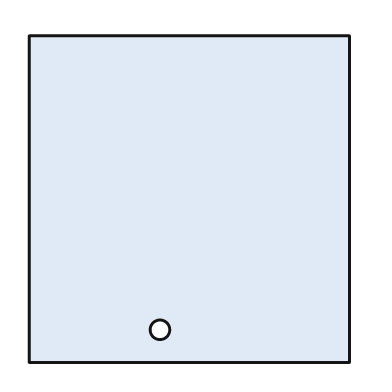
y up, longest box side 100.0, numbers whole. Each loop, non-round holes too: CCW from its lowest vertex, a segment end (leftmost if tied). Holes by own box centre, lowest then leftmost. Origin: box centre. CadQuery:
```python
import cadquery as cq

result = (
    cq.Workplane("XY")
    .moveTo(-49.0, -50.0)
    .lineTo(49.0, -50.0)
    .lineTo(49.0, 50.0)
    .lineTo(-49.0, 50.0)
    .close()
    .moveTo(-9.0, -40.0)
    .circle(3.0)
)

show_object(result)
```